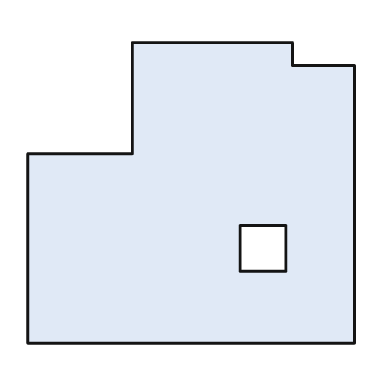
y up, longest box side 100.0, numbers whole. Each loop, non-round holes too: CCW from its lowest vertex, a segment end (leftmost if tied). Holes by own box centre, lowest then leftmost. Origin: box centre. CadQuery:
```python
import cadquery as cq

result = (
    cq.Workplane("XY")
    .moveTo(-50.0, -46.0)
    .lineTo(50.0, -46.0)
    .lineTo(50.0, 39.0)
    .lineTo(31.0, 39.0)
    .lineTo(31.0, 46.0)
    .lineTo(-18.0, 46.0)
    .lineTo(-18.0, 12.0)
    .lineTo(-50.0, 12.0)
    .close()
    .moveTo(15.0, -24.0)
    .lineTo(29.0, -24.0)
    .lineTo(29.0, -10.0)
    .lineTo(15.0, -10.0)
    .close()
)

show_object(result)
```